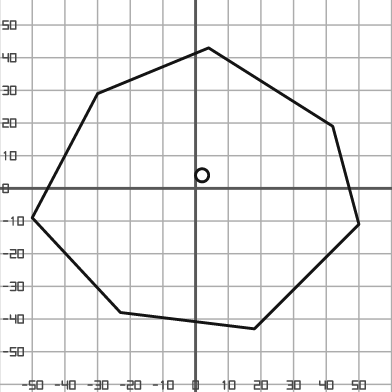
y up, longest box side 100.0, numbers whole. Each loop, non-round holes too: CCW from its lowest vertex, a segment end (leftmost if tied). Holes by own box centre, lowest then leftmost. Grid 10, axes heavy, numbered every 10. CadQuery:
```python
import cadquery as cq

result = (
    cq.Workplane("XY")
    .moveTo(18.0, -43.0)
    .lineTo(50.0, -11.0)
    .lineTo(42.0, 19.0)
    .lineTo(4.0, 43.0)
    .lineTo(-30.0, 29.0)
    .lineTo(-50.0, -9.0)
    .lineTo(-23.0, -38.0)
    .close()
    .moveTo(2.0, 4.0)
    .circle(2.0)
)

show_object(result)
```